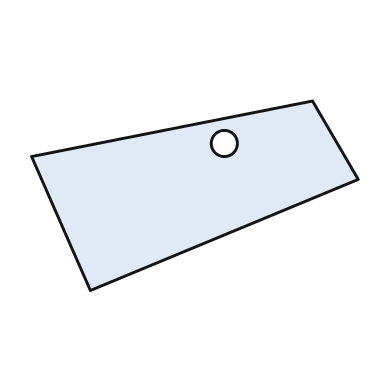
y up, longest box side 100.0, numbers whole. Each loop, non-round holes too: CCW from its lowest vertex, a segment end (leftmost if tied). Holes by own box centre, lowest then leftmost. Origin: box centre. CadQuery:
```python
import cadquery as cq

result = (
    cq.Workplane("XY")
    .moveTo(-32.0, -29.0)
    .lineTo(50.0, 5.0)
    .lineTo(36.0, 29.0)
    .lineTo(-50.0, 12.0)
    .close()
    .moveTo(9.0, 16.0)
    .circle(4.0)
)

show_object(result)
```